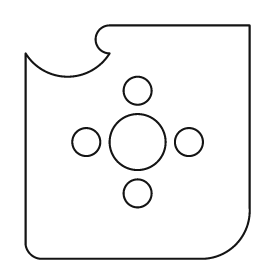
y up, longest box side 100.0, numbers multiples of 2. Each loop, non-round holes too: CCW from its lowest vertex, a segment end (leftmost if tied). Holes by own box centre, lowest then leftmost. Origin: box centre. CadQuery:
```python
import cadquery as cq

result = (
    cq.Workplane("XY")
    .moveTo(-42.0, -50.0)
    .lineTo(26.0, -50.0)
    .threePointArc((42.0, -44.0), (48.0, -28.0))
    .lineTo(48.0, 50.0)
    .lineTo(-12.0, 50.0)
    .threePointArc((-18.0, 44.0), (-12.0, 38.0))
    .threePointArc((-30.0, 28.0), (-48.0, 38.0))
    .lineTo(-48.0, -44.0)
    .threePointArc((-46.0, -48.0), (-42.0, -50.0))
    .close()
    .moveTo(0.0, -22.0)
    .circle(6.0)
    .moveTo(-22.0, 0.0)
    .circle(6.0)
    .moveTo(0.0, 0.0)
    .circle(12.0)
    .moveTo(22.0, 0.0)
    .circle(6.0)
    .moveTo(0.0, 22.0)
    .circle(6.0)
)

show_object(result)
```